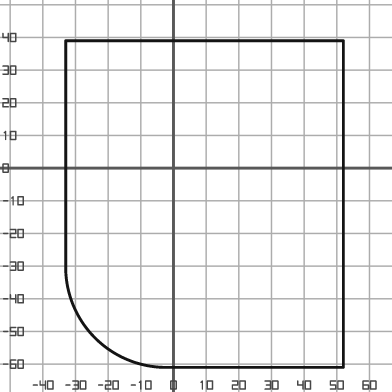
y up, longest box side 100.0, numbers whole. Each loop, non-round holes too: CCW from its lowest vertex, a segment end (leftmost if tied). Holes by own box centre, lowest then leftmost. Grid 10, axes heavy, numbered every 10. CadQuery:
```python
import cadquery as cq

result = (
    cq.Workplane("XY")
    .moveTo(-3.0, -61.0)
    .lineTo(52.0, -61.0)
    .lineTo(52.0, 39.0)
    .lineTo(-33.0, 39.0)
    .lineTo(-33.0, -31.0)
    .threePointArc((-24.0, -52.0), (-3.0, -61.0))
    .close()
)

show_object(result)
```